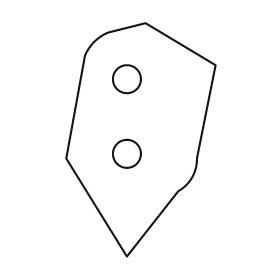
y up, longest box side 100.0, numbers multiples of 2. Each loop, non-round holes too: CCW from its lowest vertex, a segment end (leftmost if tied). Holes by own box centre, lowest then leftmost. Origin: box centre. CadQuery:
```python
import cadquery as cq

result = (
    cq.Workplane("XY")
    .moveTo(-6.0, -50.0)
    .lineTo(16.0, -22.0)
    .threePointArc((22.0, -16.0), (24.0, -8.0))
    .lineTo(32.0, 32.0)
    .lineTo(2.0, 50.0)
    .lineTo(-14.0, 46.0)
    .threePointArc((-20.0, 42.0), (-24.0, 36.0))
    .lineTo(-32.0, -8.0)
    .close()
    .moveTo(-6.0, -6.0)
    .circle(6.0)
    .moveTo(-6.0, 26.0)
    .circle(6.0)
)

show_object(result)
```